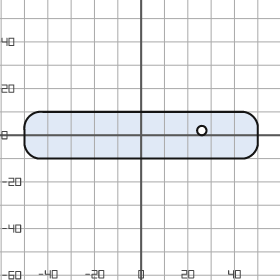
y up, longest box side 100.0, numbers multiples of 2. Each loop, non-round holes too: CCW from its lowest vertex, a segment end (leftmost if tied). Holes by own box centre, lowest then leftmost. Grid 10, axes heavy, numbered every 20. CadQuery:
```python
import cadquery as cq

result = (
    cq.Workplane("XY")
    .moveTo(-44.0, -10.0)
    .lineTo(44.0, -10.0)
    .threePointArc((48.0, -8.0), (50.0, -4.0))
    .lineTo(50.0, 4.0)
    .threePointArc((48.0, 8.0), (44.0, 10.0))
    .lineTo(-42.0, 10.0)
    .threePointArc((-48.0, 8.0), (-50.0, 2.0))
    .lineTo(-50.0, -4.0)
    .threePointArc((-48.0, -8.0), (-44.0, -10.0))
    .close()
    .moveTo(26.0, 2.0)
    .circle(2.0)
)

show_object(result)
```